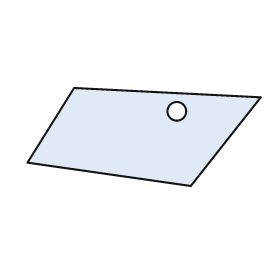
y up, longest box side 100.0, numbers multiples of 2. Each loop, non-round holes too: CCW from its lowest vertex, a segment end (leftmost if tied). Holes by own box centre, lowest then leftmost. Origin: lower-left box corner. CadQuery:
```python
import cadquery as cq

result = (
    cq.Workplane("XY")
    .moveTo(70.0, 0.0)
    .lineTo(100.0, 38.0)
    .lineTo(20.0, 42.0)
    .lineTo(0.0, 10.0)
    .close()
    .moveTo(64.0, 32.0)
    .circle(4.0)
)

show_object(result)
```